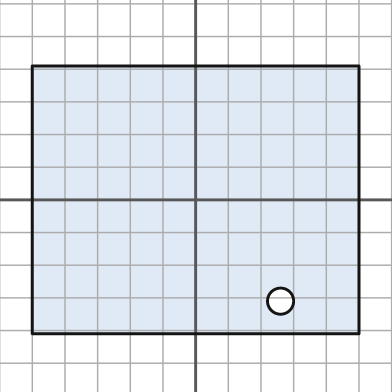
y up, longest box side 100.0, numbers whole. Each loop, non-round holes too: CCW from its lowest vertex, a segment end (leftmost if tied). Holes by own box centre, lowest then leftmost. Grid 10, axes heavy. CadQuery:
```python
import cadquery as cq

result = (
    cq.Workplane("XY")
    .moveTo(-50.0, -41.0)
    .lineTo(50.0, -41.0)
    .lineTo(50.0, 41.0)
    .lineTo(-50.0, 41.0)
    .close()
    .moveTo(26.0, -31.0)
    .circle(4.0)
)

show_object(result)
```